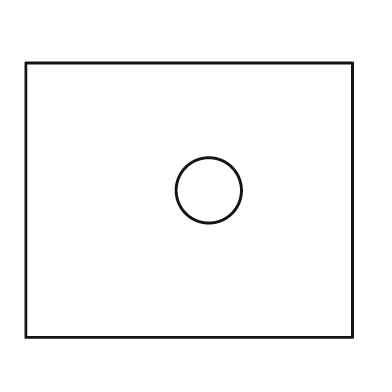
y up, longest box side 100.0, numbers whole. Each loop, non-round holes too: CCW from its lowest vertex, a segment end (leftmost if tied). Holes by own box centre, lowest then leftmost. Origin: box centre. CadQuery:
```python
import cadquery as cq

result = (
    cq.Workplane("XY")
    .moveTo(-50.0, -42.0)
    .lineTo(50.0, -42.0)
    .lineTo(50.0, 42.0)
    .lineTo(-50.0, 42.0)
    .close()
    .moveTo(6.0, 3.0)
    .circle(10.0)
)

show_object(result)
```